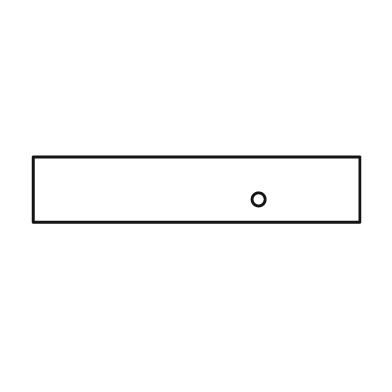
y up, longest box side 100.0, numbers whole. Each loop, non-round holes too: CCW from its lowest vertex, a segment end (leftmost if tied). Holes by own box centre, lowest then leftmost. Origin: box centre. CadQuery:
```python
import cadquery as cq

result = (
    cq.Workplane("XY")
    .moveTo(-50.0, -10.0)
    .lineTo(50.0, -10.0)
    .lineTo(50.0, 10.0)
    .lineTo(-50.0, 10.0)
    .close()
    .moveTo(19.0, -3.0)
    .circle(2.0)
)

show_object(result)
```